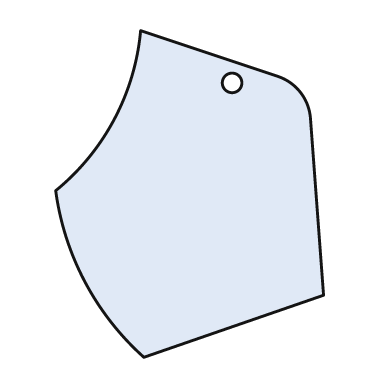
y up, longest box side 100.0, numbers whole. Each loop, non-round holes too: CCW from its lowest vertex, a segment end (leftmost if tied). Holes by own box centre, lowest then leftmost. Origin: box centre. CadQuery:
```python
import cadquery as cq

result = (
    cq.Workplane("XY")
    .moveTo(-14.0, -50.0)
    .lineTo(41.0, -31.0)
    .lineTo(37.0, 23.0)
    .threePointArc((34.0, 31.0), (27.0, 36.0))
    .lineTo(-15.0, 50.0)
    .threePointArc((-23.0, 23.0), (-41.0, 1.0))
    .threePointArc((-32.0, -27.0), (-14.0, -50.0))
    .close()
    .moveTo(13.0, 34.0)
    .circle(3.0)
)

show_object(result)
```